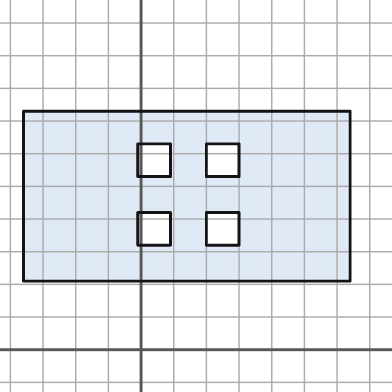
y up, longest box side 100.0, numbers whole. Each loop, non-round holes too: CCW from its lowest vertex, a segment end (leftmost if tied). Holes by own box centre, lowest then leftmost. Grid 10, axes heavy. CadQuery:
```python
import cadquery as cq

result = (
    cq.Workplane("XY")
    .moveTo(-36.0, 21.0)
    .lineTo(64.0, 21.0)
    .lineTo(64.0, 73.0)
    .lineTo(-36.0, 73.0)
    .close()
    .moveTo(-1.0, 32.0)
    .lineTo(9.0, 32.0)
    .lineTo(9.0, 42.0)
    .lineTo(-1.0, 42.0)
    .close()
    .moveTo(20.0, 32.0)
    .lineTo(30.0, 32.0)
    .lineTo(30.0, 42.0)
    .lineTo(20.0, 42.0)
    .close()
    .moveTo(-1.0, 53.0)
    .lineTo(9.0, 53.0)
    .lineTo(9.0, 63.0)
    .lineTo(-1.0, 63.0)
    .close()
    .moveTo(20.0, 53.0)
    .lineTo(30.0, 53.0)
    .lineTo(30.0, 63.0)
    .lineTo(20.0, 63.0)
    .close()
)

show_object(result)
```